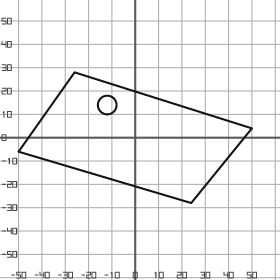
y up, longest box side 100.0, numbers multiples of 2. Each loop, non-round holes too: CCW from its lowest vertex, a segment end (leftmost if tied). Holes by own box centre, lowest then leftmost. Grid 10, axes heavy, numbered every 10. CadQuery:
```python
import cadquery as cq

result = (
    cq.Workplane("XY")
    .moveTo(24.0, -28.0)
    .lineTo(50.0, 4.0)
    .lineTo(-26.0, 28.0)
    .lineTo(-50.0, -6.0)
    .close()
    .moveTo(-12.0, 14.0)
    .circle(4.0)
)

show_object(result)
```